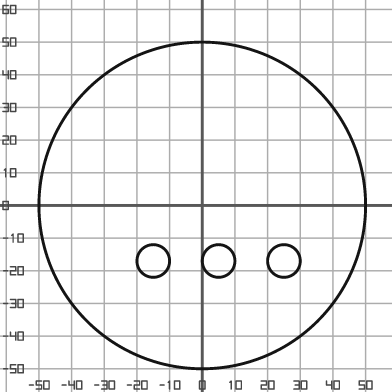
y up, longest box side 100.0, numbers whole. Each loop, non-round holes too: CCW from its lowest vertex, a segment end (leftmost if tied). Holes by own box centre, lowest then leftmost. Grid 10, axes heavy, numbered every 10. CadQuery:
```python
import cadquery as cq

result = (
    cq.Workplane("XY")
    .moveTo(0.0, 0.0)
    .circle(50.0)
    .moveTo(-15.0, -17.0)
    .circle(5.0)
    .moveTo(5.0, -17.0)
    .circle(5.0)
    .moveTo(25.0, -17.0)
    .circle(5.0)
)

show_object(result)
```